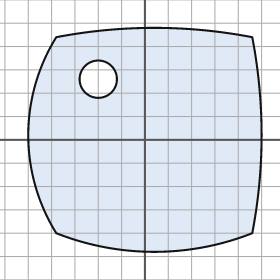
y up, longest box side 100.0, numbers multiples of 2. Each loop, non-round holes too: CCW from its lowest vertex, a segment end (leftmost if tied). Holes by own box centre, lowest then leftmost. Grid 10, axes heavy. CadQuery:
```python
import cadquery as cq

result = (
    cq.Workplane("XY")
    .moveTo(-38.0, -40.0)
    .threePointArc((4.0, -48.0), (46.0, -40.0))
    .threePointArc((50.0, 2.0), (46.0, 44.0))
    .threePointArc((4.0, 48.0), (-38.0, 44.0))
    .threePointArc((-50.0, 2.0), (-38.0, -40.0))
    .close()
    .moveTo(-20.0, 26.0)
    .circle(8.0)
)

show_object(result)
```